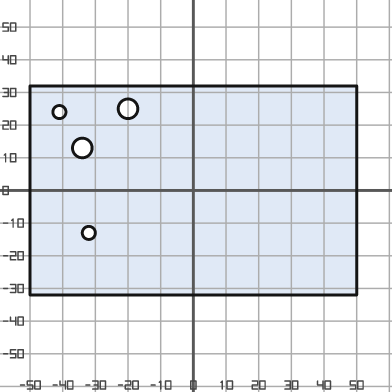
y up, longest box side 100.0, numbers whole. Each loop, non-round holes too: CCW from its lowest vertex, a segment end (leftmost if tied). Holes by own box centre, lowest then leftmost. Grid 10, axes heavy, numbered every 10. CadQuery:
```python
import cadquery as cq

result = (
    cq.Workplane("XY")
    .moveTo(-50.0, -32.0)
    .lineTo(50.0, -32.0)
    .lineTo(50.0, 32.0)
    .lineTo(-50.0, 32.0)
    .close()
    .moveTo(-32.0, -13.0)
    .circle(2.0)
    .moveTo(-34.0, 13.0)
    .circle(3.0)
    .moveTo(-41.0, 24.0)
    .circle(2.0)
    .moveTo(-20.0, 25.0)
    .circle(3.0)
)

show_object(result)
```